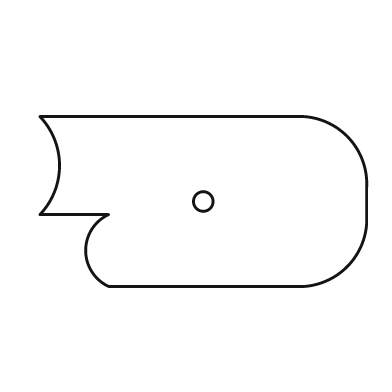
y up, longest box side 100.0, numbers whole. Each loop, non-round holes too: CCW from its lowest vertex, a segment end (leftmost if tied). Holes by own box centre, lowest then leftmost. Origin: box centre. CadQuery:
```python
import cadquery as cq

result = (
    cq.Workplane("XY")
    .moveTo(-29.0, -26.0)
    .lineTo(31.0, -26.0)
    .threePointArc((44.0, -20.0), (50.0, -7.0))
    .lineTo(50.0, 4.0)
    .threePointArc((44.0, 20.0), (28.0, 26.0))
    .lineTo(-50.0, 26.0)
    .threePointArc((-44.0, 11.0), (-50.0, -4.0))
    .lineTo(-29.0, -4.0)
    .threePointArc((-36.0, -15.0), (-29.0, -26.0))
    .close()
    .moveTo(0.0, 0.0)
    .circle(3.0)
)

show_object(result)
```